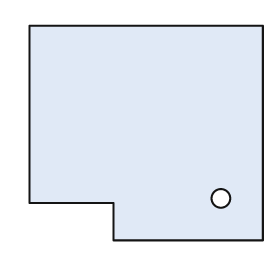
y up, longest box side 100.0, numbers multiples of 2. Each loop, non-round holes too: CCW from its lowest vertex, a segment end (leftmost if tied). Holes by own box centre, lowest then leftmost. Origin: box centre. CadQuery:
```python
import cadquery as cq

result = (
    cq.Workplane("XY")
    .moveTo(-14.0, -46.0)
    .lineTo(50.0, -46.0)
    .lineTo(50.0, 46.0)
    .lineTo(-50.0, 46.0)
    .lineTo(-50.0, -30.0)
    .lineTo(-14.0, -30.0)
    .close()
    .moveTo(32.0, -28.0)
    .circle(4.0)
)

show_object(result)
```